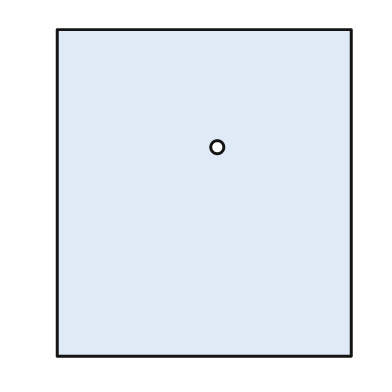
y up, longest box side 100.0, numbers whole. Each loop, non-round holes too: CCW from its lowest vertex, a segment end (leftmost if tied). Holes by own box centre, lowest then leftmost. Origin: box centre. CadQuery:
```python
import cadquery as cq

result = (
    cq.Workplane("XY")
    .moveTo(-45.0, -50.0)
    .lineTo(45.0, -50.0)
    .lineTo(45.0, 50.0)
    .lineTo(-45.0, 50.0)
    .close()
    .moveTo(4.0, 14.0)
    .circle(2.0)
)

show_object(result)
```